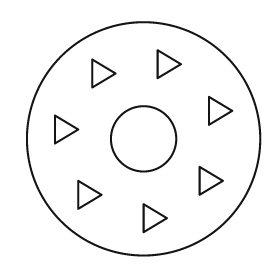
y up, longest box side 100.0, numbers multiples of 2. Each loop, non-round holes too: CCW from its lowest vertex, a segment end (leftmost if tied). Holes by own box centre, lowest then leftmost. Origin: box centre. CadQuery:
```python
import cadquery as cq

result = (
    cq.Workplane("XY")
    .moveTo(0.0, 0.0)
    .circle(50.0)
    .moveTo(0.0, -40.0)
    .lineTo(10.0, -34.0)
    .lineTo(0.0, -28.0)
    .close()
    .moveTo(-28.0, -30.0)
    .lineTo(-18.0, -24.0)
    .lineTo(-28.0, -18.0)
    .close()
    .moveTo(24.0, -24.0)
    .lineTo(34.0, -18.0)
    .lineTo(24.0, -12.0)
    .close()
    .moveTo(0.0, 0.0)
    .circle(14.0)
    .moveTo(-38.0, -2.0)
    .lineTo(-28.0, 4.0)
    .lineTo(-38.0, 10.0)
    .close()
    .moveTo(28.0, 6.0)
    .lineTo(38.0, 12.0)
    .lineTo(28.0, 18.0)
    .close()
    .moveTo(-22.0, 22.0)
    .lineTo(-12.0, 28.0)
    .lineTo(-22.0, 34.0)
    .close()
    .moveTo(6.0, 26.0)
    .lineTo(16.0, 32.0)
    .lineTo(6.0, 38.0)
    .close()
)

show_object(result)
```